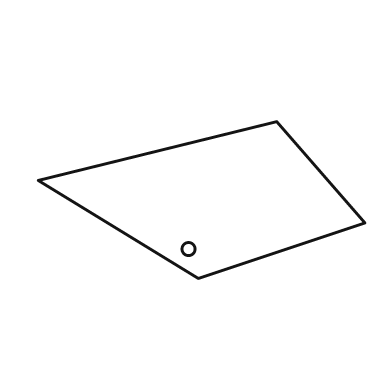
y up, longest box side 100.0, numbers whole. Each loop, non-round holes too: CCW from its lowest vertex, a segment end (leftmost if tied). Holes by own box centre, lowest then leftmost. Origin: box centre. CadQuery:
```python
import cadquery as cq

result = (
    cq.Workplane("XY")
    .moveTo(-1.0, -24.0)
    .lineTo(50.0, -7.0)
    .lineTo(23.0, 24.0)
    .lineTo(-50.0, 6.0)
    .close()
    .moveTo(-4.0, -15.0)
    .circle(2.0)
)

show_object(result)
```